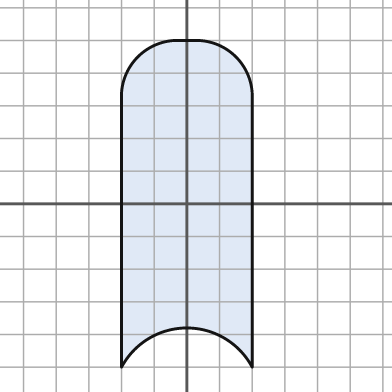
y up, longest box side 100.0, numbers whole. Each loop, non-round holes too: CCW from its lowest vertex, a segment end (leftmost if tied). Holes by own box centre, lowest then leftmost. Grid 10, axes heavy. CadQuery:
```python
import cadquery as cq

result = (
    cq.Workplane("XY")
    .moveTo(-20.0, -50.0)
    .threePointArc((0.0, -38.0), (20.0, -50.0))
    .lineTo(20.0, 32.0)
    .threePointArc((15.0, 45.0), (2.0, 50.0))
    .lineTo(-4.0, 50.0)
    .threePointArc((-15.0, 45.0), (-20.0, 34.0))
    .close()
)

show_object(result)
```